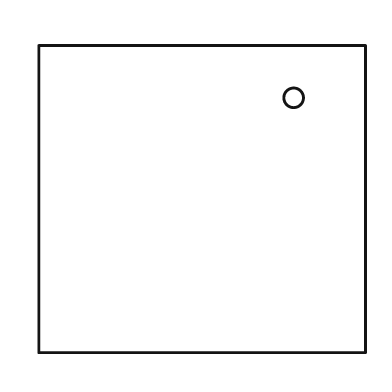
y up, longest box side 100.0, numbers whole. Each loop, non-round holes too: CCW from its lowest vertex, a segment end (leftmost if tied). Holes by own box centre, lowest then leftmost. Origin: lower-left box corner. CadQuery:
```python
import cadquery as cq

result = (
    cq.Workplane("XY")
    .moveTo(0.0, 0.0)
    .lineTo(100.0, 0.0)
    .lineTo(100.0, 94.0)
    .lineTo(0.0, 94.0)
    .close()
    .moveTo(78.0, 78.0)
    .circle(3.0)
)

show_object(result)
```